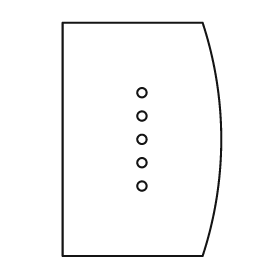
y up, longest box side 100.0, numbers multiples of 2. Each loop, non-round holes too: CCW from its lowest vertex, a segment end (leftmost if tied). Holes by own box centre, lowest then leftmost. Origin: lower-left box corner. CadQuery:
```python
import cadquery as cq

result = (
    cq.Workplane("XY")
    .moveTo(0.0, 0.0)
    .lineTo(60.0, 0.0)
    .threePointArc((68.0, 50.0), (60.0, 100.0))
    .lineTo(0.0, 100.0)
    .close()
    .moveTo(34.0, 30.0)
    .circle(2.0)
    .moveTo(34.0, 40.0)
    .circle(2.0)
    .moveTo(34.0, 50.0)
    .circle(2.0)
    .moveTo(34.0, 60.0)
    .circle(2.0)
    .moveTo(34.0, 70.0)
    .circle(2.0)
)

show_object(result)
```